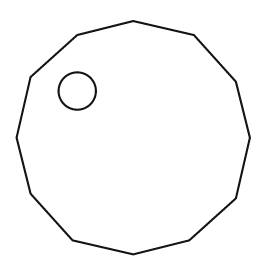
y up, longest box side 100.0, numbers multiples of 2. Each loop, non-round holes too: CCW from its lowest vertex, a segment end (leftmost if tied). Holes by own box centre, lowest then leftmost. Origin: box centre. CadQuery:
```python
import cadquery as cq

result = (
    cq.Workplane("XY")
    .moveTo(0.0, -50.0)
    .lineTo(24.0, -44.0)
    .lineTo(44.0, -26.0)
    .lineTo(50.0, 0.0)
    .lineTo(44.0, 24.0)
    .lineTo(26.0, 44.0)
    .lineTo(0.0, 50.0)
    .lineTo(-24.0, 44.0)
    .lineTo(-44.0, 26.0)
    .lineTo(-50.0, 0.0)
    .lineTo(-44.0, -24.0)
    .lineTo(-26.0, -44.0)
    .close()
    .moveTo(-24.0, 20.0)
    .circle(8.0)
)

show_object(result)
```